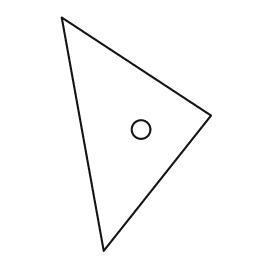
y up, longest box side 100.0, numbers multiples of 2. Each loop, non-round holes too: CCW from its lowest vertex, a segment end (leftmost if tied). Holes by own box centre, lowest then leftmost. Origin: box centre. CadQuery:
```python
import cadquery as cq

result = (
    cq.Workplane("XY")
    .moveTo(-14.0, -50.0)
    .lineTo(32.0, 8.0)
    .lineTo(-32.0, 50.0)
    .close()
    .moveTo(2.0, 2.0)
    .circle(4.0)
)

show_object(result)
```